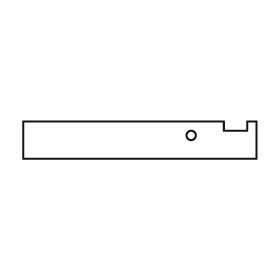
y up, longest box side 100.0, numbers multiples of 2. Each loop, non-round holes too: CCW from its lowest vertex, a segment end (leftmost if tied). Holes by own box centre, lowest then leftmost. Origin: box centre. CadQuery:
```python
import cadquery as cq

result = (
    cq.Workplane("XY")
    .moveTo(-50.0, -8.0)
    .lineTo(50.0, -8.0)
    .lineTo(50.0, 8.0)
    .lineTo(46.0, 8.0)
    .lineTo(46.0, 4.0)
    .lineTo(36.0, 4.0)
    .lineTo(36.0, 8.0)
    .lineTo(-50.0, 8.0)
    .close()
    .moveTo(22.0, 2.0)
    .circle(2.0)
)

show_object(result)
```